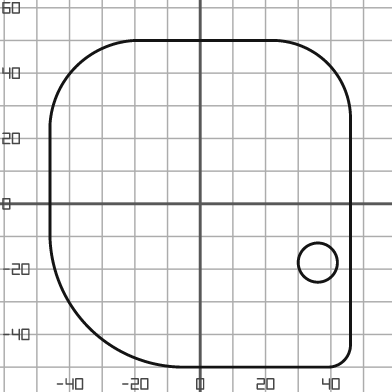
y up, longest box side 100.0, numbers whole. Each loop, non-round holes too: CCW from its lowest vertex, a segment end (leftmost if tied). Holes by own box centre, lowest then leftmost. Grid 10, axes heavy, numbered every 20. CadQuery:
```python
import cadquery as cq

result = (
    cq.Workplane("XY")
    .moveTo(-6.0, -50.0)
    .lineTo(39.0, -50.0)
    .threePointArc((44.0, -48.0), (46.0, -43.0))
    .lineTo(46.0, 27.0)
    .threePointArc((39.0, 43.0), (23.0, 50.0))
    .lineTo(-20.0, 50.0)
    .threePointArc((-38.0, 42.0), (-46.0, 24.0))
    .lineTo(-46.0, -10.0)
    .threePointArc((-34.0, -38.0), (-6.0, -50.0))
    .close()
    .moveTo(36.0, -18.0)
    .circle(6.0)
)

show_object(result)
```